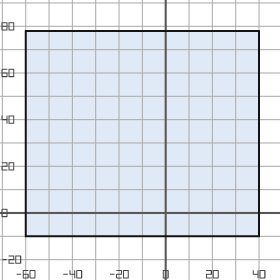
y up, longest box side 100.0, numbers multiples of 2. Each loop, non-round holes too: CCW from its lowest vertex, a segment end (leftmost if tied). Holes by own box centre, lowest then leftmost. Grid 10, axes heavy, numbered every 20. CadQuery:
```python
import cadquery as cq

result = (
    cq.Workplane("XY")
    .moveTo(-60.0, -10.0)
    .lineTo(40.0, -10.0)
    .lineTo(40.0, 78.0)
    .lineTo(-60.0, 78.0)
    .close()
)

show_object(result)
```